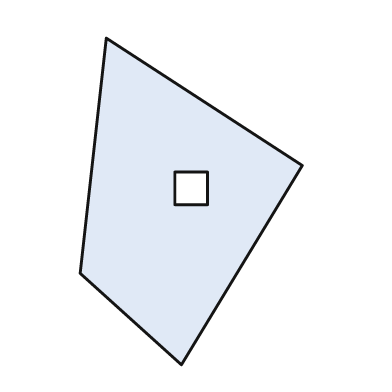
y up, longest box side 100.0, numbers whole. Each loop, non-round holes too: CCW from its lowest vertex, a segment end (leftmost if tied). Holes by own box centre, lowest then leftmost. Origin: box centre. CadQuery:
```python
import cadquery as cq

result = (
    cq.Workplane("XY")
    .moveTo(-3.0, -50.0)
    .lineTo(34.0, 11.0)
    .lineTo(-26.0, 50.0)
    .lineTo(-34.0, -22.0)
    .close()
    .moveTo(-5.0, -1.0)
    .lineTo(5.0, -1.0)
    .lineTo(5.0, 9.0)
    .lineTo(-5.0, 9.0)
    .close()
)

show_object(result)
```